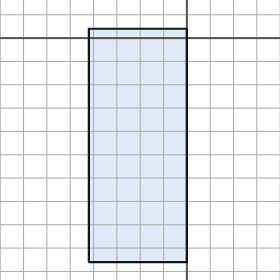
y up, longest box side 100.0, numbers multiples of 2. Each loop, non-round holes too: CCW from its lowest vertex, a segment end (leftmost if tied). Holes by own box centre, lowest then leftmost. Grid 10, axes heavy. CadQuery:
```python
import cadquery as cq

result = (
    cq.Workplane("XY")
    .moveTo(-42.0, -96.0)
    .lineTo(0.0, -96.0)
    .lineTo(0.0, 4.0)
    .lineTo(-42.0, 4.0)
    .close()
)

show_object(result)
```